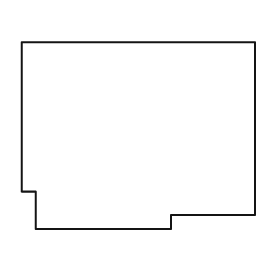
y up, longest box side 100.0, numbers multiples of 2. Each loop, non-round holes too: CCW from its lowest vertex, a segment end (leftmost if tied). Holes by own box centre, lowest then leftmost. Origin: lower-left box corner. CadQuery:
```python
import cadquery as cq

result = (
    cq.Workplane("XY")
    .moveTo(6.0, 0.0)
    .lineTo(64.0, 0.0)
    .lineTo(64.0, 6.0)
    .lineTo(100.0, 6.0)
    .lineTo(100.0, 80.0)
    .lineTo(0.0, 80.0)
    .lineTo(0.0, 16.0)
    .lineTo(6.0, 16.0)
    .close()
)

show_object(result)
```